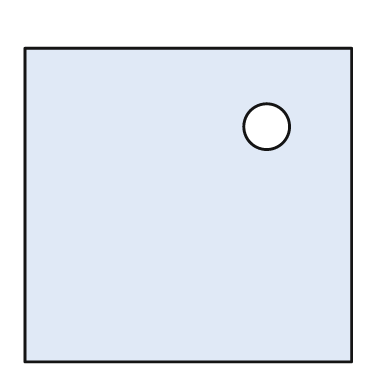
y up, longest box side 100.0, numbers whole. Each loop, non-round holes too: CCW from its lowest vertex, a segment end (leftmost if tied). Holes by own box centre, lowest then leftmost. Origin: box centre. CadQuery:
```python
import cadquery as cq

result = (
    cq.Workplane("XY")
    .moveTo(-50.0, -48.0)
    .lineTo(50.0, -48.0)
    .lineTo(50.0, 48.0)
    .lineTo(-50.0, 48.0)
    .close()
    .moveTo(24.0, 24.0)
    .circle(7.0)
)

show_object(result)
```